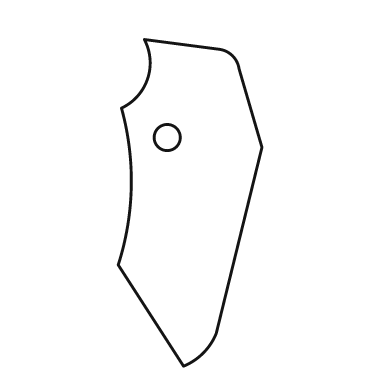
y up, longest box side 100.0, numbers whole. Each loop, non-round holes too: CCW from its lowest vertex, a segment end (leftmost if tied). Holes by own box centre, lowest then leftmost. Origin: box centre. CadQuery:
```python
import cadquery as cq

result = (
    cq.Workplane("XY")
    .moveTo(-2.0, -50.0)
    .threePointArc((4.0, -46.0), (8.0, -40.0))
    .lineTo(22.0, 17.0)
    .lineTo(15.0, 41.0)
    .threePointArc((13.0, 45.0), (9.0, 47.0))
    .lineTo(-14.0, 50.0)
    .threePointArc((-13.0, 38.0), (-21.0, 29.0))
    .threePointArc((-18.0, 5.0), (-22.0, -19.0))
    .close()
    .moveTo(-7.0, 20.0)
    .circle(4.0)
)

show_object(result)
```